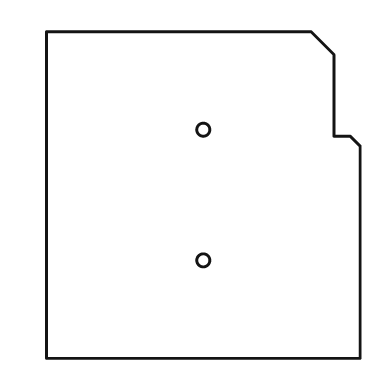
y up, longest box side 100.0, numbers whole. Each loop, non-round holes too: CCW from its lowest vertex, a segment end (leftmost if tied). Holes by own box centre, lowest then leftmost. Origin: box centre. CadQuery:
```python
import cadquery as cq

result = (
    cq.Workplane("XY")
    .moveTo(-48.0, -50.0)
    .lineTo(48.0, -50.0)
    .lineTo(48.0, 15.0)
    .lineTo(45.0, 18.0)
    .lineTo(40.0, 18.0)
    .lineTo(40.0, 43.0)
    .lineTo(33.0, 50.0)
    .lineTo(-48.0, 50.0)
    .close()
    .moveTo(0.0, -20.0)
    .circle(2.0)
    .moveTo(0.0, 20.0)
    .circle(2.0)
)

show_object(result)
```